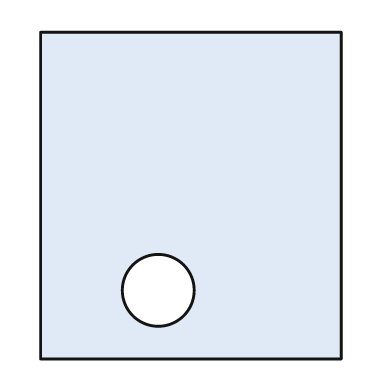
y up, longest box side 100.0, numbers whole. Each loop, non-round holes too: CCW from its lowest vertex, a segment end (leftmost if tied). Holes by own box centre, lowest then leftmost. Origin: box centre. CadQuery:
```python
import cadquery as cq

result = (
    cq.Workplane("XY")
    .moveTo(-46.0, -50.0)
    .lineTo(46.0, -50.0)
    .lineTo(46.0, 50.0)
    .lineTo(-46.0, 50.0)
    .close()
    .moveTo(-10.0, -29.0)
    .circle(11.0)
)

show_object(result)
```